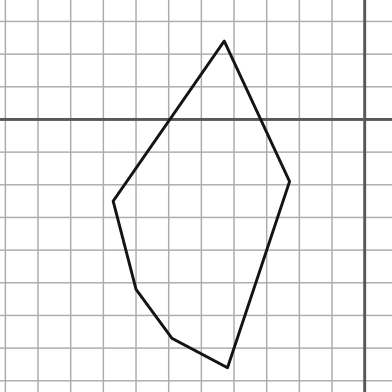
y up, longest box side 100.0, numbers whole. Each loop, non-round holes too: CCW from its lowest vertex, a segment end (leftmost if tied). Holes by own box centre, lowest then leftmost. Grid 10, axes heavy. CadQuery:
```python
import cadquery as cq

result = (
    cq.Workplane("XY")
    .moveTo(-42.0, -76.0)
    .lineTo(-23.0, -19.0)
    .lineTo(-43.0, 24.0)
    .lineTo(-77.0, -25.0)
    .lineTo(-70.0, -52.0)
    .lineTo(-59.0, -67.0)
    .close()
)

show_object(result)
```